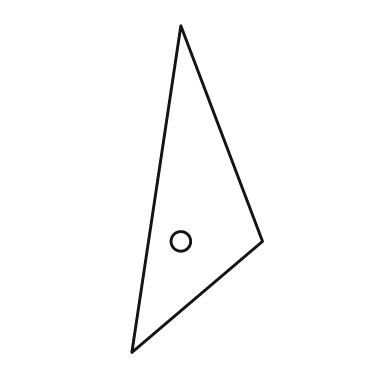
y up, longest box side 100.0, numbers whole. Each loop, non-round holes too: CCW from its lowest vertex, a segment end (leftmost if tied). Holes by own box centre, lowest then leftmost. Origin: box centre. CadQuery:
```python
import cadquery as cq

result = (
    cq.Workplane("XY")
    .moveTo(-20.0, -50.0)
    .lineTo(20.0, -16.0)
    .lineTo(-5.0, 50.0)
    .close()
    .moveTo(-5.0, -16.0)
    .circle(3.0)
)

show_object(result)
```